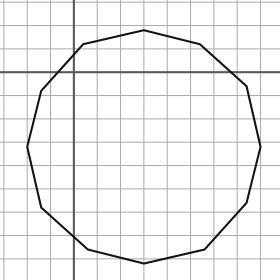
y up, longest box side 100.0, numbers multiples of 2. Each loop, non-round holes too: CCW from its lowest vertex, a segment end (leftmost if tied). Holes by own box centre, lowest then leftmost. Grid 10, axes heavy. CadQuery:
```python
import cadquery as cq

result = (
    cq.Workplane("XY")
    .moveTo(30.0, -82.0)
    .lineTo(56.0, -76.0)
    .lineTo(74.0, -56.0)
    .lineTo(80.0, -32.0)
    .lineTo(74.0, -6.0)
    .lineTo(54.0, 12.0)
    .lineTo(30.0, 18.0)
    .lineTo(4.0, 12.0)
    .lineTo(-14.0, -8.0)
    .lineTo(-20.0, -32.0)
    .lineTo(-14.0, -58.0)
    .lineTo(6.0, -76.0)
    .close()
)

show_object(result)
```